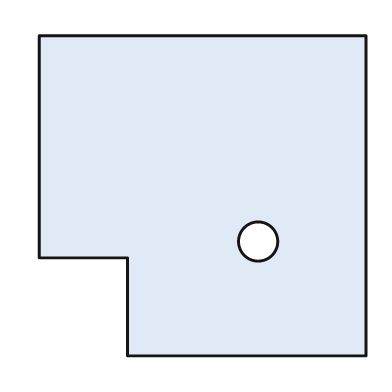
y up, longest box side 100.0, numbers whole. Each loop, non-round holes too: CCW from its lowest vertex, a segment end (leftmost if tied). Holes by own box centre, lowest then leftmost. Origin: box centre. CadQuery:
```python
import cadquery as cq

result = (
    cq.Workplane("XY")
    .moveTo(-23.0, -49.0)
    .lineTo(50.0, -49.0)
    .lineTo(50.0, 49.0)
    .lineTo(-50.0, 49.0)
    .lineTo(-50.0, -19.0)
    .lineTo(-23.0, -19.0)
    .close()
    .moveTo(17.0, -14.0)
    .circle(6.0)
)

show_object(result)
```